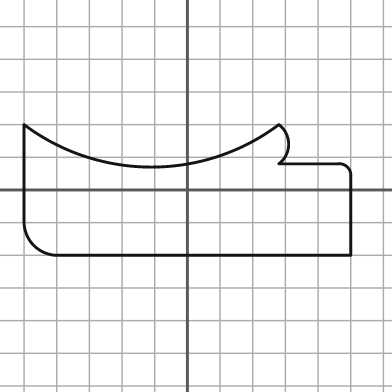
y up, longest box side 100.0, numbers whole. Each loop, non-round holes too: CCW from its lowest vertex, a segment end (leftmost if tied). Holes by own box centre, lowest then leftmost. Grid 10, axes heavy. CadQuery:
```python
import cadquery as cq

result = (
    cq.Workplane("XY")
    .moveTo(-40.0, -20.0)
    .lineTo(50.0, -20.0)
    .lineTo(50.0, 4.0)
    .threePointArc((49.0, 7.0), (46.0, 8.0))
    .lineTo(28.0, 8.0)
    .threePointArc((31.0, 14.0), (28.0, 20.0))
    .threePointArc((-11.0, 7.0), (-50.0, 20.0))
    .lineTo(-50.0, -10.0)
    .threePointArc((-47.0, -17.0), (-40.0, -20.0))
    .close()
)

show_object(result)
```